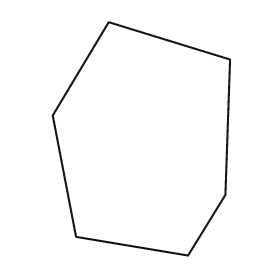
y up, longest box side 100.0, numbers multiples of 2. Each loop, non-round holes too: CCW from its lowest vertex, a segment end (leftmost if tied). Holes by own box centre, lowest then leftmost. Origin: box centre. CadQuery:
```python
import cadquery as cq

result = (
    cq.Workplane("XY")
    .moveTo(20.0, -50.0)
    .lineTo(36.0, -24.0)
    .lineTo(38.0, 34.0)
    .lineTo(-14.0, 50.0)
    .lineTo(-38.0, 10.0)
    .lineTo(-28.0, -42.0)
    .close()
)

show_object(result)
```